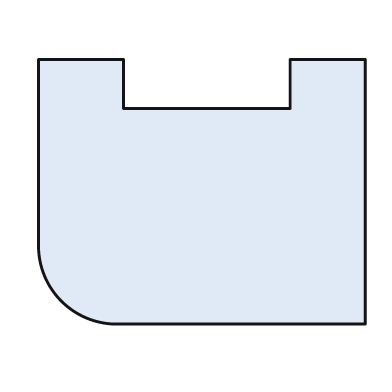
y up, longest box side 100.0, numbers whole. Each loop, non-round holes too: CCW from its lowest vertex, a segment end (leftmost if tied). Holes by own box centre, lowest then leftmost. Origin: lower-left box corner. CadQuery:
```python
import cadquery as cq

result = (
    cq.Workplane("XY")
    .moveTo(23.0, 0.0)
    .lineTo(100.0, 0.0)
    .lineTo(100.0, 81.0)
    .lineTo(77.0, 81.0)
    .lineTo(77.0, 66.0)
    .lineTo(26.0, 66.0)
    .lineTo(26.0, 81.0)
    .lineTo(0.0, 81.0)
    .lineTo(0.0, 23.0)
    .threePointArc((7.0, 7.0), (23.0, 0.0))
    .close()
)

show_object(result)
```